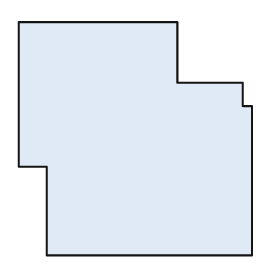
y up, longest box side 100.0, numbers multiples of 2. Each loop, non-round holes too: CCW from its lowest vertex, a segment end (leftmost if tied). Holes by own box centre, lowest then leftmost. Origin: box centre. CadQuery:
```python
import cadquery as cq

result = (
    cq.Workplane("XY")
    .moveTo(-38.0, -50.0)
    .lineTo(50.0, -50.0)
    .lineTo(50.0, 14.0)
    .lineTo(46.0, 14.0)
    .lineTo(46.0, 24.0)
    .lineTo(18.0, 24.0)
    .lineTo(18.0, 50.0)
    .lineTo(-50.0, 50.0)
    .lineTo(-50.0, -12.0)
    .lineTo(-38.0, -12.0)
    .close()
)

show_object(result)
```